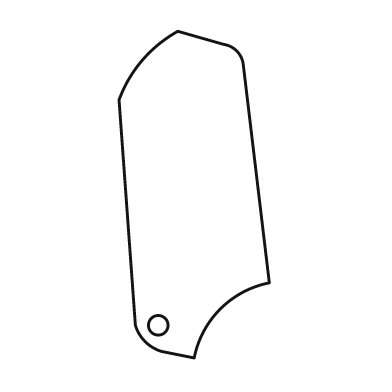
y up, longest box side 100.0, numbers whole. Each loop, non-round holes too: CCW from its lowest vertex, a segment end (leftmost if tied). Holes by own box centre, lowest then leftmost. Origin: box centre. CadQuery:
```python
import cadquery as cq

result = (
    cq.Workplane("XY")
    .moveTo(0.0, -50.0)
    .threePointArc((8.0, -35.0), (23.0, -27.0))
    .lineTo(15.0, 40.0)
    .threePointArc((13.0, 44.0), (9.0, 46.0))
    .lineTo(-5.0, 50.0)
    .threePointArc((-16.0, 41.0), (-23.0, 29.0))
    .lineTo(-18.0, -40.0)
    .threePointArc((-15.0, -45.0), (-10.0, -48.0))
    .close()
    .moveTo(-11.0, -40.0)
    .circle(3.0)
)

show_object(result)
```